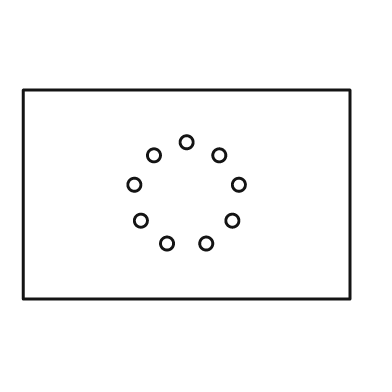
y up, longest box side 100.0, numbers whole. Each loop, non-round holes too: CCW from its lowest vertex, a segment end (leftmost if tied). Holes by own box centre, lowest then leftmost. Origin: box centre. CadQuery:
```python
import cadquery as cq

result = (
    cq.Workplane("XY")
    .moveTo(-50.0, -32.0)
    .lineTo(50.0, -32.0)
    .lineTo(50.0, 32.0)
    .lineTo(-50.0, 32.0)
    .close()
    .moveTo(-6.0, -15.0)
    .circle(2.0)
    .moveTo(6.0, -15.0)
    .circle(2.0)
    .moveTo(-14.0, -8.0)
    .circle(2.0)
    .moveTo(14.0, -8.0)
    .circle(2.0)
    .moveTo(-16.0, 3.0)
    .circle(2.0)
    .moveTo(16.0, 3.0)
    .circle(2.0)
    .moveTo(-10.0, 12.0)
    .circle(2.0)
    .moveTo(10.0, 12.0)
    .circle(2.0)
    .moveTo(0.0, 16.0)
    .circle(2.0)
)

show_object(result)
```